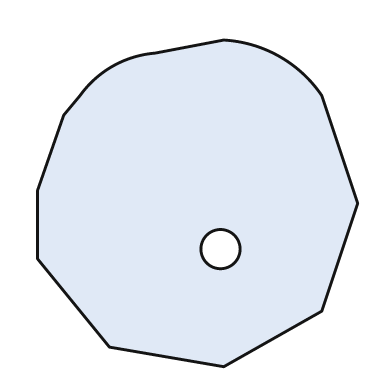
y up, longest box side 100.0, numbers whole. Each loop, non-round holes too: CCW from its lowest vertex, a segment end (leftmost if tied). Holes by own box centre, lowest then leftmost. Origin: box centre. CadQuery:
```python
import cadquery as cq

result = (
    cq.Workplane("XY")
    .moveTo(8.0, -50.0)
    .lineTo(38.0, -33.0)
    .lineTo(49.0, 0.0)
    .lineTo(38.0, 33.0)
    .threePointArc((25.0, 45.0), (8.0, 50.0))
    .lineTo(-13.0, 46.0)
    .threePointArc((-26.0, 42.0), (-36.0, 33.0))
    .lineTo(-41.0, 27.0)
    .lineTo(-49.0, 4.0)
    .lineTo(-49.0, -17.0)
    .lineTo(-27.0, -44.0)
    .close()
    .moveTo(7.0, -14.0)
    .circle(6.0)
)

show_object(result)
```